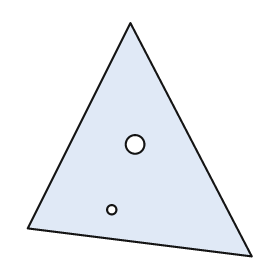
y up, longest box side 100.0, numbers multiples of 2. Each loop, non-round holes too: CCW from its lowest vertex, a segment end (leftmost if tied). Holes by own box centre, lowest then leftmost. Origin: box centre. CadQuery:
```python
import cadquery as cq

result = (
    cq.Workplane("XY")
    .moveTo(48.0, -50.0)
    .lineTo(-4.0, 50.0)
    .lineTo(-48.0, -38.0)
    .close()
    .moveTo(-12.0, -30.0)
    .circle(2.0)
    .moveTo(-2.0, -2.0)
    .circle(4.0)
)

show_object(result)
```